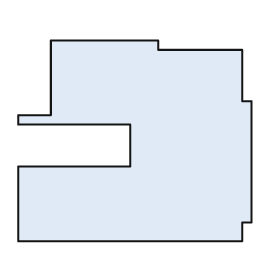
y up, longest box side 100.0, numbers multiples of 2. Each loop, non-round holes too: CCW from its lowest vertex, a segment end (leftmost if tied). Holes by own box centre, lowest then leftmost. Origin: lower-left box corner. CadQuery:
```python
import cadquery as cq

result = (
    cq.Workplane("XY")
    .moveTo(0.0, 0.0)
    .lineTo(96.0, 0.0)
    .lineTo(96.0, 8.0)
    .lineTo(100.0, 8.0)
    .lineTo(100.0, 60.0)
    .lineTo(96.0, 60.0)
    .lineTo(96.0, 82.0)
    .lineTo(60.0, 82.0)
    .lineTo(60.0, 86.0)
    .lineTo(14.0, 86.0)
    .lineTo(14.0, 54.0)
    .lineTo(0.0, 54.0)
    .lineTo(0.0, 50.0)
    .lineTo(48.0, 50.0)
    .lineTo(48.0, 32.0)
    .lineTo(0.0, 32.0)
    .close()
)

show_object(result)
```